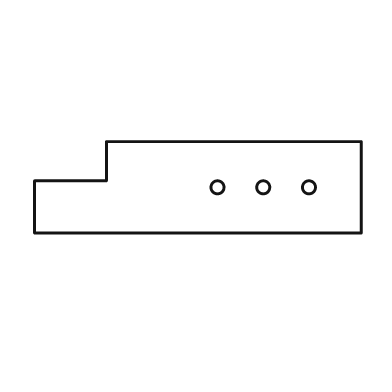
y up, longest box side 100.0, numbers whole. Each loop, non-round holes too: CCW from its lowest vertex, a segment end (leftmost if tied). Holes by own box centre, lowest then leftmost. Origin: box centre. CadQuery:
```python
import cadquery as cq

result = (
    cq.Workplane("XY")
    .moveTo(-50.0, -14.0)
    .lineTo(50.0, -14.0)
    .lineTo(50.0, 14.0)
    .lineTo(-28.0, 14.0)
    .lineTo(-28.0, 2.0)
    .lineTo(-50.0, 2.0)
    .close()
    .moveTo(6.0, 0.0)
    .circle(2.0)
    .moveTo(20.0, 0.0)
    .circle(2.0)
    .moveTo(34.0, 0.0)
    .circle(2.0)
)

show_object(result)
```